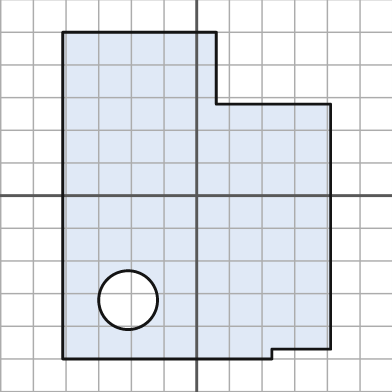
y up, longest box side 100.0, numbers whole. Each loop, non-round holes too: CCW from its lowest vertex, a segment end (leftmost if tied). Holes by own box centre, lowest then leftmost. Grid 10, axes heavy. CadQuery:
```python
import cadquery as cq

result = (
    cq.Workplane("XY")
    .moveTo(-41.0, -50.0)
    .lineTo(23.0, -50.0)
    .lineTo(23.0, -47.0)
    .lineTo(41.0, -47.0)
    .lineTo(41.0, 28.0)
    .lineTo(6.0, 28.0)
    .lineTo(6.0, 50.0)
    .lineTo(-41.0, 50.0)
    .close()
    .moveTo(-21.0, -32.0)
    .circle(9.0)
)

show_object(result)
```